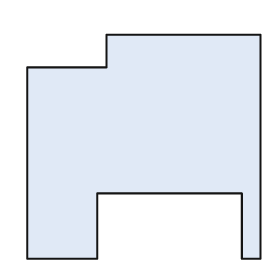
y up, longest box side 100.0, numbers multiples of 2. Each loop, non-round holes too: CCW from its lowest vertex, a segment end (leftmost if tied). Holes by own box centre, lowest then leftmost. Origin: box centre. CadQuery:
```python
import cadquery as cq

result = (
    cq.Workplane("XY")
    .moveTo(-50.0, -48.0)
    .lineTo(-20.0, -48.0)
    .lineTo(-20.0, -20.0)
    .lineTo(42.0, -20.0)
    .lineTo(42.0, -48.0)
    .lineTo(50.0, -48.0)
    .lineTo(50.0, 48.0)
    .lineTo(-16.0, 48.0)
    .lineTo(-16.0, 34.0)
    .lineTo(-50.0, 34.0)
    .close()
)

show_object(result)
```